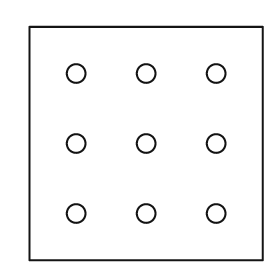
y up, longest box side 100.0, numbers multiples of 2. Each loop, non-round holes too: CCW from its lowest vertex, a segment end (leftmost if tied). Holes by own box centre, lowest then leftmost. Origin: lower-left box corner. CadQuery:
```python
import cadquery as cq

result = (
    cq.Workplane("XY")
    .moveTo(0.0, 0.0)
    .lineTo(100.0, 0.0)
    .lineTo(100.0, 100.0)
    .lineTo(0.0, 100.0)
    .close()
    .moveTo(20.0, 20.0)
    .circle(4.0)
    .moveTo(50.0, 20.0)
    .circle(4.0)
    .moveTo(80.0, 20.0)
    .circle(4.0)
    .moveTo(20.0, 50.0)
    .circle(4.0)
    .moveTo(50.0, 50.0)
    .circle(4.0)
    .moveTo(80.0, 50.0)
    .circle(4.0)
    .moveTo(20.0, 80.0)
    .circle(4.0)
    .moveTo(50.0, 80.0)
    .circle(4.0)
    .moveTo(80.0, 80.0)
    .circle(4.0)
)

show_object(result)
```